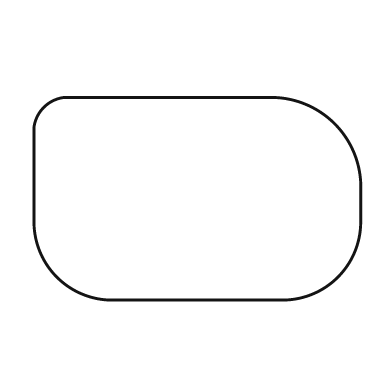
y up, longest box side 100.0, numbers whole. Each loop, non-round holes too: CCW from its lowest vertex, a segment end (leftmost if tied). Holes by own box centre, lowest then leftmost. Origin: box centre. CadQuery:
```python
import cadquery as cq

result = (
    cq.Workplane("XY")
    .moveTo(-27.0, -31.0)
    .lineTo(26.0, -31.0)
    .threePointArc((43.0, -24.0), (50.0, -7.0))
    .lineTo(50.0, 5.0)
    .threePointArc((42.0, 23.0), (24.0, 31.0))
    .lineTo(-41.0, 31.0)
    .threePointArc((-47.0, 28.0), (-50.0, 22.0))
    .lineTo(-50.0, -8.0)
    .threePointArc((-43.0, -24.0), (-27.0, -31.0))
    .close()
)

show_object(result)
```